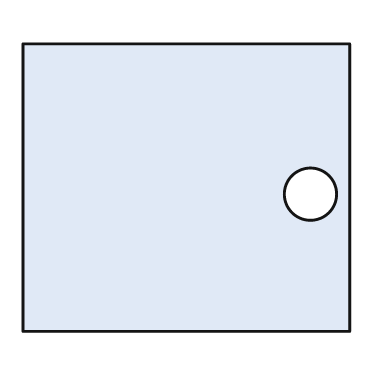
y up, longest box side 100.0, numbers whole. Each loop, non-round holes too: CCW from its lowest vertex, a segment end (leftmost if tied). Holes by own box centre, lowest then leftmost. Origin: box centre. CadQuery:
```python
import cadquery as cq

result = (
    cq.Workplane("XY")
    .moveTo(-50.0, -44.0)
    .lineTo(50.0, -44.0)
    .lineTo(50.0, 44.0)
    .lineTo(-50.0, 44.0)
    .close()
    .moveTo(38.0, -2.0)
    .circle(8.0)
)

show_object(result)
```